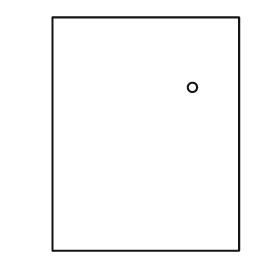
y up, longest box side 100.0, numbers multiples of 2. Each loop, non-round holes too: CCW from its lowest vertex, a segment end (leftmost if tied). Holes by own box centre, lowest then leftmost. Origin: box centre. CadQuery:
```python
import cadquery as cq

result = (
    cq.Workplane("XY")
    .moveTo(-40.0, -50.0)
    .lineTo(40.0, -50.0)
    .lineTo(40.0, 50.0)
    .lineTo(-40.0, 50.0)
    .close()
    .moveTo(20.0, 20.0)
    .circle(2.0)
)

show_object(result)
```